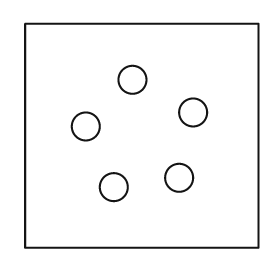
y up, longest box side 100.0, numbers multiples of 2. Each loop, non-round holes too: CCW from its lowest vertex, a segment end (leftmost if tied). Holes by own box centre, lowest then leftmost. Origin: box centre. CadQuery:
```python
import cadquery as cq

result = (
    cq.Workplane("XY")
    .moveTo(-50.0, -48.0)
    .lineTo(50.0, -48.0)
    .lineTo(50.0, 48.0)
    .lineTo(-50.0, 48.0)
    .close()
    .moveTo(-12.0, -22.0)
    .circle(6.0)
    .moveTo(16.0, -18.0)
    .circle(6.0)
    .moveTo(-24.0, 4.0)
    .circle(6.0)
    .moveTo(22.0, 10.0)
    .circle(6.0)
    .moveTo(-4.0, 24.0)
    .circle(6.0)
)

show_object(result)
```